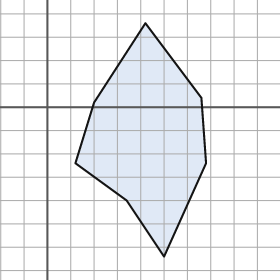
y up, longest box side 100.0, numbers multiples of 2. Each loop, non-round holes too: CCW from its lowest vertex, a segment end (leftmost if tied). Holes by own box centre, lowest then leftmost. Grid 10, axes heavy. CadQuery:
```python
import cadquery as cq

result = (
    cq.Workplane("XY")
    .moveTo(50.0, -64.0)
    .lineTo(68.0, -24.0)
    .lineTo(66.0, 4.0)
    .lineTo(42.0, 36.0)
    .lineTo(20.0, 2.0)
    .lineTo(12.0, -24.0)
    .lineTo(34.0, -40.0)
    .close()
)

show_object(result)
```